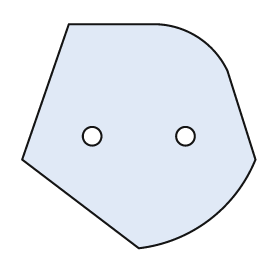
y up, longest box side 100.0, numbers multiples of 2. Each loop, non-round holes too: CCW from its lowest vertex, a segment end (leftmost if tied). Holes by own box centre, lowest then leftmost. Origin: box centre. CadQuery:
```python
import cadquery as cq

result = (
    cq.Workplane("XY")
    .moveTo(0.0, -48.0)
    .threePointArc((30.0, -36.0), (50.0, -10.0))
    .lineTo(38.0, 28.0)
    .threePointArc((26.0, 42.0), (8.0, 48.0))
    .lineTo(-30.0, 48.0)
    .lineTo(-50.0, -10.0)
    .close()
    .moveTo(-20.0, 0.0)
    .circle(4.0)
    .moveTo(20.0, 0.0)
    .circle(4.0)
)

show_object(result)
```